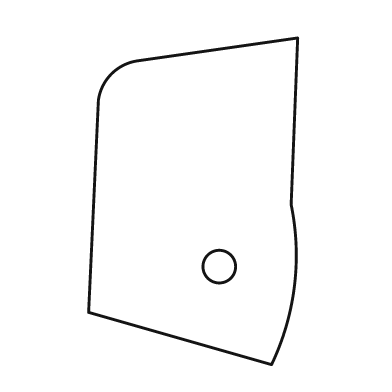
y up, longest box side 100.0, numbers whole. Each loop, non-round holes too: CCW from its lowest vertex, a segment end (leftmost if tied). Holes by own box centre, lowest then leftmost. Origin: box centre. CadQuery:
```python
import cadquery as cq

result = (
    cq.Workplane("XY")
    .moveTo(24.0, -50.0)
    .threePointArc((31.0, -26.0), (30.0, -1.0))
    .lineTo(32.0, 50.0)
    .lineTo(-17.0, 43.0)
    .threePointArc((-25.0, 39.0), (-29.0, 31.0))
    .lineTo(-32.0, -34.0)
    .close()
    .moveTo(8.0, -20.0)
    .circle(5.0)
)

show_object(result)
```